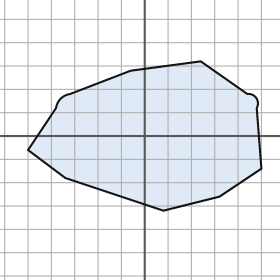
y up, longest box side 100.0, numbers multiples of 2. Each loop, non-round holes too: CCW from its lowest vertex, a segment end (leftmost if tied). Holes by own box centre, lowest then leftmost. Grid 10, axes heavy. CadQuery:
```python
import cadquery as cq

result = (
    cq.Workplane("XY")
    .moveTo(8.0, -32.0)
    .lineTo(32.0, -26.0)
    .lineTo(50.0, -14.0)
    .lineTo(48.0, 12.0)
    .threePointArc((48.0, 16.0), (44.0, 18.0))
    .lineTo(24.0, 32.0)
    .lineTo(-6.0, 28.0)
    .lineTo(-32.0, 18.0)
    .threePointArc((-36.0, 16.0), (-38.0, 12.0))
    .lineTo(-50.0, -6.0)
    .lineTo(-34.0, -18.0)
    .close()
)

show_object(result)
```